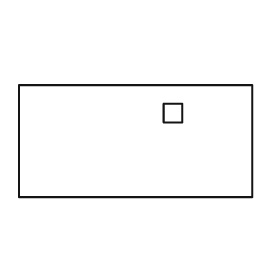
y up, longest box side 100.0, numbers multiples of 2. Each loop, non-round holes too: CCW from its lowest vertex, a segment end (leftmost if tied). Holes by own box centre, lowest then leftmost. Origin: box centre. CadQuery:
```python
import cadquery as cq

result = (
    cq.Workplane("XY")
    .moveTo(-50.0, -24.0)
    .lineTo(50.0, -24.0)
    .lineTo(50.0, 24.0)
    .lineTo(-50.0, 24.0)
    .close()
    .moveTo(12.0, 8.0)
    .lineTo(20.0, 8.0)
    .lineTo(20.0, 16.0)
    .lineTo(12.0, 16.0)
    .close()
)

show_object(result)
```